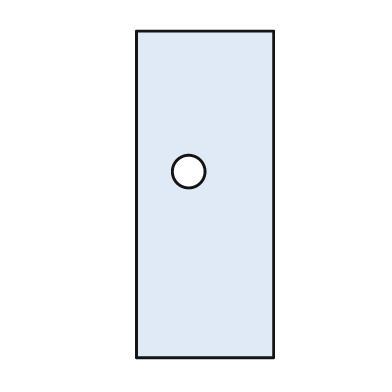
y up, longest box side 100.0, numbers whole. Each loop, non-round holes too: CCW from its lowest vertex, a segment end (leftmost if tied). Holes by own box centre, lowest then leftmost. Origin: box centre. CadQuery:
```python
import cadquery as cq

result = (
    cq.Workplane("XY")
    .moveTo(-21.0, -50.0)
    .lineTo(21.0, -50.0)
    .lineTo(21.0, 50.0)
    .lineTo(-21.0, 50.0)
    .close()
    .moveTo(-5.0, 7.0)
    .circle(5.0)
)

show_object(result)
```